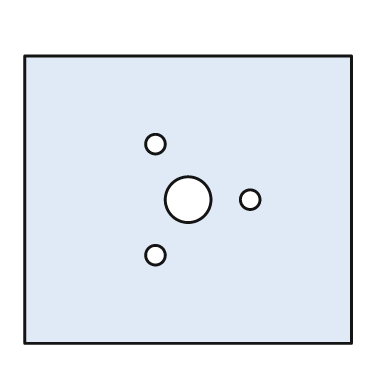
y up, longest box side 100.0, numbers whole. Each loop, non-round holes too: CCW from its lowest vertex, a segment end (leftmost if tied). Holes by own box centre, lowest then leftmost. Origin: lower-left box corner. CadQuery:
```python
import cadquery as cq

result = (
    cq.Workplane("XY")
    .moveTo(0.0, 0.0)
    .lineTo(100.0, 0.0)
    .lineTo(100.0, 88.0)
    .lineTo(0.0, 88.0)
    .close()
    .moveTo(40.0, 27.0)
    .circle(3.0)
    .moveTo(50.0, 44.0)
    .circle(7.0)
    .moveTo(69.0, 44.0)
    .circle(3.0)
    .moveTo(40.0, 61.0)
    .circle(3.0)
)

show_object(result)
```